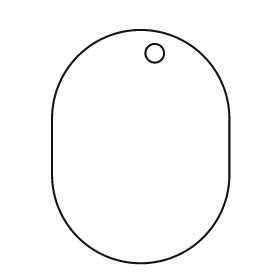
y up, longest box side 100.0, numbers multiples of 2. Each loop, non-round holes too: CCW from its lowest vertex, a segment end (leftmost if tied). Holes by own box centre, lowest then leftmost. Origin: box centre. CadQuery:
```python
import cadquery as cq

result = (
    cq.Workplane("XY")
    .moveTo(-38.0, -12.0)
    .threePointArc((0.0, -50.0), (38.0, -12.0))
    .lineTo(38.0, 12.0)
    .threePointArc((0.0, 50.0), (-38.0, 12.0))
    .close()
    .moveTo(6.0, 40.0)
    .circle(4.0)
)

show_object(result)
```